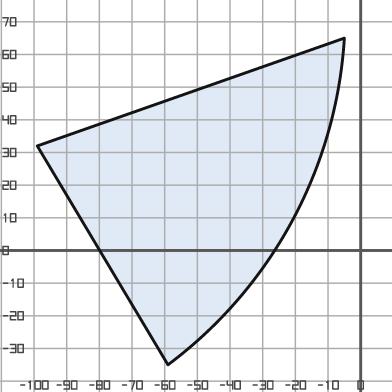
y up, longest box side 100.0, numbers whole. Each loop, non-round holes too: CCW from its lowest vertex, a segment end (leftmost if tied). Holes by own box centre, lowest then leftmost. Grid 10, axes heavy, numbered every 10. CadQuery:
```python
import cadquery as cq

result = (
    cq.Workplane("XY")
    .moveTo(-59.0, -35.0)
    .threePointArc((-21.0, 9.0), (-5.0, 65.0))
    .lineTo(-99.0, 32.0)
    .close()
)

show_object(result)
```